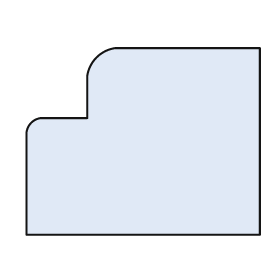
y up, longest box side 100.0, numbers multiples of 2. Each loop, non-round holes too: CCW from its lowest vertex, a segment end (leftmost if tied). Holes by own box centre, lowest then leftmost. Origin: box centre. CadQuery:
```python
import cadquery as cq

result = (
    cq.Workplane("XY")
    .moveTo(-50.0, -40.0)
    .lineTo(50.0, -40.0)
    .lineTo(50.0, 40.0)
    .lineTo(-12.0, 40.0)
    .threePointArc((-20.0, 36.0), (-24.0, 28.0))
    .lineTo(-24.0, 10.0)
    .lineTo(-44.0, 10.0)
    .threePointArc((-48.0, 8.0), (-50.0, 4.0))
    .close()
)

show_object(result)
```